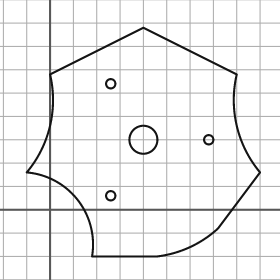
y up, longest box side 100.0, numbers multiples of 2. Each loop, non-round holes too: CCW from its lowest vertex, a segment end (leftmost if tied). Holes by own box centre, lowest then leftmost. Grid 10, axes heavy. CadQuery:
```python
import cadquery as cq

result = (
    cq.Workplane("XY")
    .moveTo(18.0, -20.0)
    .lineTo(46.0, -20.0)
    .threePointArc((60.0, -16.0), (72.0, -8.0))
    .lineTo(90.0, 16.0)
    .threePointArc((80.0, 36.0), (80.0, 58.0))
    .lineTo(40.0, 78.0)
    .lineTo(0.0, 58.0)
    .threePointArc((0.0, 36.0), (-10.0, 16.0))
    .threePointArc((12.0, 4.0), (18.0, -20.0))
    .close()
    .moveTo(26.0, 6.0)
    .circle(2.0)
    .moveTo(40.0, 30.0)
    .circle(6.0)
    .moveTo(68.0, 30.0)
    .circle(2.0)
    .moveTo(26.0, 54.0)
    .circle(2.0)
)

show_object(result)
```